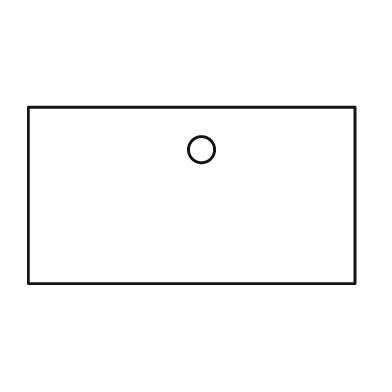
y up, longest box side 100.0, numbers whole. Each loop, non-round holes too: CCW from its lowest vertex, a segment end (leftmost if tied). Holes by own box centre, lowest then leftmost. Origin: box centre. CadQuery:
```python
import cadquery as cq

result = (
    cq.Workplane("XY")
    .moveTo(-50.0, -27.0)
    .lineTo(50.0, -27.0)
    .lineTo(50.0, 27.0)
    .lineTo(-50.0, 27.0)
    .close()
    .moveTo(3.0, 14.0)
    .circle(4.0)
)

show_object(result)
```